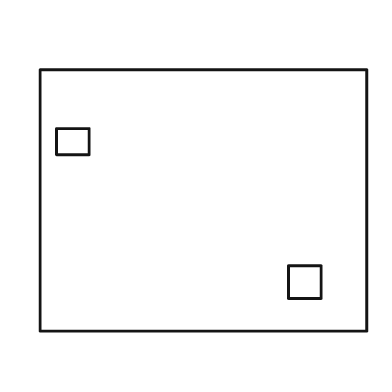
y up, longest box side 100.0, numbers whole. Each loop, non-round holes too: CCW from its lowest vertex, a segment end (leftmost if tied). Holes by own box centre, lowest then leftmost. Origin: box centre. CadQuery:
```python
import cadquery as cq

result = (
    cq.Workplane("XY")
    .moveTo(-50.0, -40.0)
    .lineTo(50.0, -40.0)
    .lineTo(50.0, 40.0)
    .lineTo(-50.0, 40.0)
    .close()
    .moveTo(26.0, -30.0)
    .lineTo(36.0, -30.0)
    .lineTo(36.0, -20.0)
    .lineTo(26.0, -20.0)
    .close()
    .moveTo(-45.0, 14.0)
    .lineTo(-35.0, 14.0)
    .lineTo(-35.0, 22.0)
    .lineTo(-45.0, 22.0)
    .close()
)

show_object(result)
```